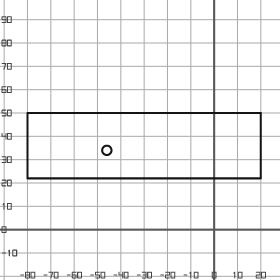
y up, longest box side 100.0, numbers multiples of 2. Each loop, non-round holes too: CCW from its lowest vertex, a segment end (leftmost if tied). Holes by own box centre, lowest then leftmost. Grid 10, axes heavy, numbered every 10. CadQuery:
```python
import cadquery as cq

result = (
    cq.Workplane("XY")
    .moveTo(-80.0, 22.0)
    .lineTo(20.0, 22.0)
    .lineTo(20.0, 50.0)
    .lineTo(-80.0, 50.0)
    .close()
    .moveTo(-46.0, 34.0)
    .circle(2.0)
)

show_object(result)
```